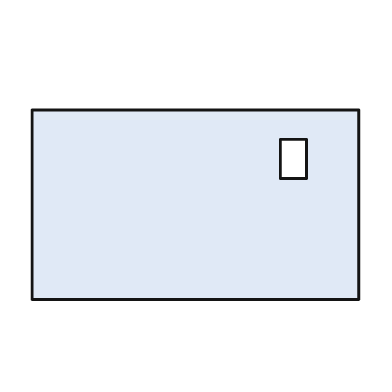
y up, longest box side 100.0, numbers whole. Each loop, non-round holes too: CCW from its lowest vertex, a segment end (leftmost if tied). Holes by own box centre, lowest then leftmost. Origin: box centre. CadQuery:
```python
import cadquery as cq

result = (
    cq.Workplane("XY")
    .moveTo(-50.0, -29.0)
    .lineTo(50.0, -29.0)
    .lineTo(50.0, 29.0)
    .lineTo(-50.0, 29.0)
    .close()
    .moveTo(26.0, 8.0)
    .lineTo(34.0, 8.0)
    .lineTo(34.0, 20.0)
    .lineTo(26.0, 20.0)
    .close()
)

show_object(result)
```